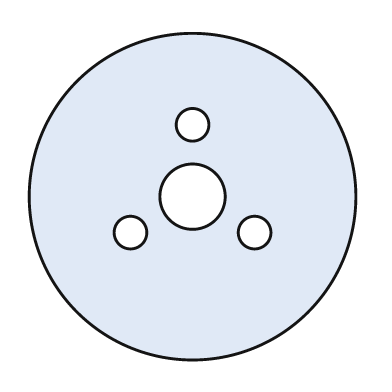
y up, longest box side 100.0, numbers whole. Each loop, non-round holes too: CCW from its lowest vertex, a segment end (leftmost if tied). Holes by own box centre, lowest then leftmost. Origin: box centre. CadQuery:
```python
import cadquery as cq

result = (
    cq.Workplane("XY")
    .moveTo(0.0, 0.0)
    .circle(50.0)
    .moveTo(-19.0, -11.0)
    .circle(5.0)
    .moveTo(19.0, -11.0)
    .circle(5.0)
    .moveTo(0.0, 0.0)
    .circle(10.0)
    .moveTo(0.0, 22.0)
    .circle(5.0)
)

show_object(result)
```